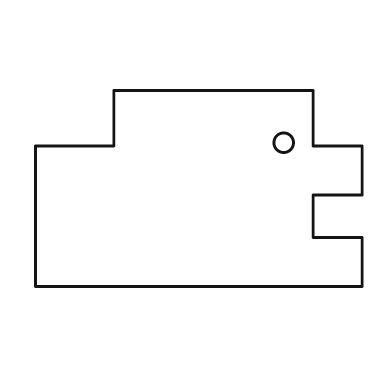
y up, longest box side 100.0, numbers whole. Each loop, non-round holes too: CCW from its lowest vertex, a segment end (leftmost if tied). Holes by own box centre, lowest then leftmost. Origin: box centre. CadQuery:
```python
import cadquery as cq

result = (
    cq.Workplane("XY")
    .moveTo(-50.0, -30.0)
    .lineTo(50.0, -30.0)
    .lineTo(50.0, -15.0)
    .lineTo(35.0, -15.0)
    .lineTo(35.0, -2.0)
    .lineTo(50.0, -2.0)
    .lineTo(50.0, 13.0)
    .lineTo(35.0, 13.0)
    .lineTo(35.0, 30.0)
    .lineTo(-26.0, 30.0)
    .lineTo(-26.0, 13.0)
    .lineTo(-50.0, 13.0)
    .close()
    .moveTo(26.0, 14.0)
    .circle(3.0)
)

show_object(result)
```